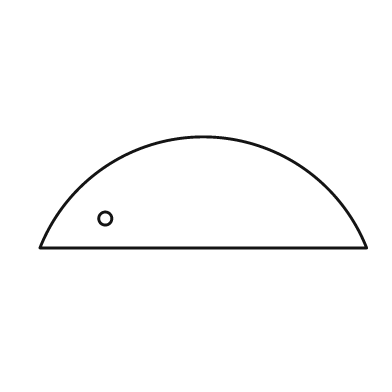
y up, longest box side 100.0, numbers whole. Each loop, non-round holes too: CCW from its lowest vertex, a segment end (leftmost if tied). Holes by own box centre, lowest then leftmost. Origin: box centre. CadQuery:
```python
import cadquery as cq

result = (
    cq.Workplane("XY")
    .moveTo(-50.0, -17.0)
    .lineTo(50.0, -17.0)
    .threePointArc((0.0, 17.0), (-50.0, -17.0))
    .close()
    .moveTo(-30.0, -8.0)
    .circle(2.0)
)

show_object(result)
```